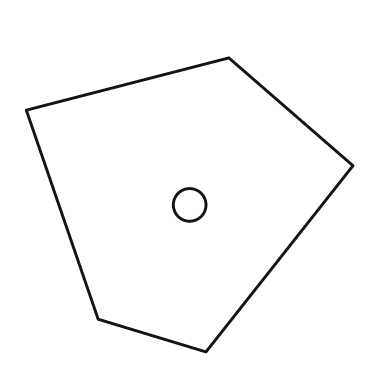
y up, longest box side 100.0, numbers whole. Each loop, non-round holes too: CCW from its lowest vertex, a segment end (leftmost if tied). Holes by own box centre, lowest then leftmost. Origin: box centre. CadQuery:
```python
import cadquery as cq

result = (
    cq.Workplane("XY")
    .moveTo(5.0, -45.0)
    .lineTo(50.0, 12.0)
    .lineTo(12.0, 45.0)
    .lineTo(-50.0, 29.0)
    .lineTo(-28.0, -35.0)
    .close()
    .moveTo(0.0, 0.0)
    .circle(5.0)
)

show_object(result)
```